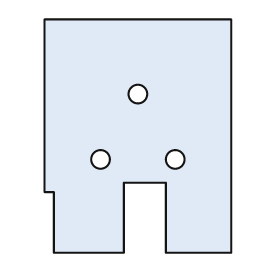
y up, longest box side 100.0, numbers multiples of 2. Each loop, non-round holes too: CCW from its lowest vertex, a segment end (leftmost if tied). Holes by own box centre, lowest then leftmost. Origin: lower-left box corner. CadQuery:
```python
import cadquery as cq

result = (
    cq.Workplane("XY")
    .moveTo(4.0, 0.0)
    .lineTo(34.0, 0.0)
    .lineTo(34.0, 30.0)
    .lineTo(52.0, 30.0)
    .lineTo(52.0, 0.0)
    .lineTo(80.0, 0.0)
    .lineTo(80.0, 100.0)
    .lineTo(0.0, 100.0)
    .lineTo(0.0, 26.0)
    .lineTo(4.0, 26.0)
    .close()
    .moveTo(24.0, 40.0)
    .circle(4.0)
    .moveTo(56.0, 40.0)
    .circle(4.0)
    .moveTo(40.0, 68.0)
    .circle(4.0)
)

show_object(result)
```